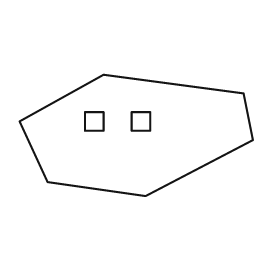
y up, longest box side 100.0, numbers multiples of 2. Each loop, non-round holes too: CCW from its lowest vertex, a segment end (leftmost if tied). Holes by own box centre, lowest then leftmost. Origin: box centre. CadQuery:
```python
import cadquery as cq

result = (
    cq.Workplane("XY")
    .moveTo(4.0, -26.0)
    .lineTo(50.0, -2.0)
    .lineTo(46.0, 18.0)
    .lineTo(-14.0, 26.0)
    .lineTo(-50.0, 6.0)
    .lineTo(-38.0, -20.0)
    .close()
    .moveTo(-22.0, 2.0)
    .lineTo(-14.0, 2.0)
    .lineTo(-14.0, 10.0)
    .lineTo(-22.0, 10.0)
    .close()
    .moveTo(-2.0, 2.0)
    .lineTo(6.0, 2.0)
    .lineTo(6.0, 10.0)
    .lineTo(-2.0, 10.0)
    .close()
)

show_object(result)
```